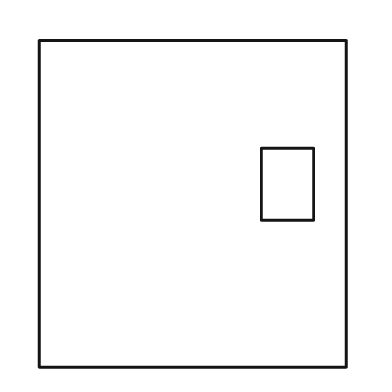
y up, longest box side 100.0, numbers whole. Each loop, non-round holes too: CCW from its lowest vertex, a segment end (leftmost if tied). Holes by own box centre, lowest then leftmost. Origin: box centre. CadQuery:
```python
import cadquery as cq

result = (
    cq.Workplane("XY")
    .moveTo(-47.0, -50.0)
    .lineTo(47.0, -50.0)
    .lineTo(47.0, 50.0)
    .lineTo(-47.0, 50.0)
    .close()
    .moveTo(21.0, -5.0)
    .lineTo(37.0, -5.0)
    .lineTo(37.0, 17.0)
    .lineTo(21.0, 17.0)
    .close()
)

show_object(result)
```